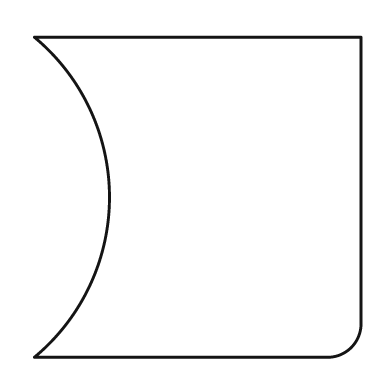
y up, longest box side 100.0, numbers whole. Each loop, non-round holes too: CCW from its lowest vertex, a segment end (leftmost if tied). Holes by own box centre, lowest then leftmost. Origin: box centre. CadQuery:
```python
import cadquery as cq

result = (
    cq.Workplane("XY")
    .moveTo(-50.0, -49.0)
    .lineTo(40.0, -49.0)
    .threePointArc((47.0, -46.0), (50.0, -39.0))
    .lineTo(50.0, 49.0)
    .lineTo(-50.0, 49.0)
    .threePointArc((-27.0, 0.0), (-50.0, -49.0))
    .close()
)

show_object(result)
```